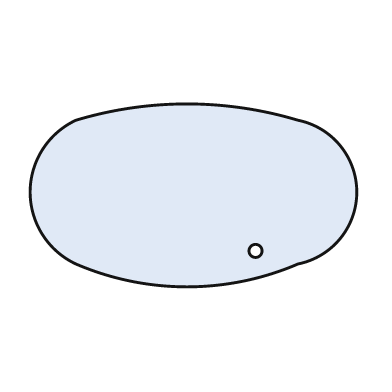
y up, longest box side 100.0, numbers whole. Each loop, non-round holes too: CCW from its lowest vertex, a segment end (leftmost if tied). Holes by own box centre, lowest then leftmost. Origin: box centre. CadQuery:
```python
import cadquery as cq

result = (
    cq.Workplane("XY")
    .moveTo(-36.0, -21.0)
    .threePointArc((-2.0, -28.0), (32.0, -21.0))
    .threePointArc((50.0, 1.0), (32.0, 23.0))
    .threePointArc((-2.0, 28.0), (-36.0, 23.0))
    .threePointArc((-50.0, 1.0), (-36.0, -21.0))
    .close()
    .moveTo(19.0, -17.0)
    .circle(2.0)
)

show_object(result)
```